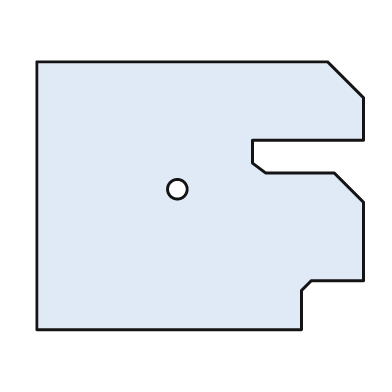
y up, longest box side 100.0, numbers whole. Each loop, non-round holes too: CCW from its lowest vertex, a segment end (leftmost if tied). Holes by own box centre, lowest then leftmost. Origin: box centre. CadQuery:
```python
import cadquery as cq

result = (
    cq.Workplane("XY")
    .moveTo(-50.0, -41.0)
    .lineTo(31.0, -41.0)
    .lineTo(31.0, -29.0)
    .lineTo(34.0, -26.0)
    .lineTo(50.0, -26.0)
    .lineTo(50.0, -2.0)
    .lineTo(41.0, 7.0)
    .lineTo(20.0, 7.0)
    .lineTo(16.0, 10.0)
    .lineTo(16.0, 17.0)
    .lineTo(50.0, 17.0)
    .lineTo(50.0, 30.0)
    .lineTo(39.0, 41.0)
    .lineTo(-50.0, 41.0)
    .close()
    .moveTo(-7.0, 2.0)
    .circle(3.0)
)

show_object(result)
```